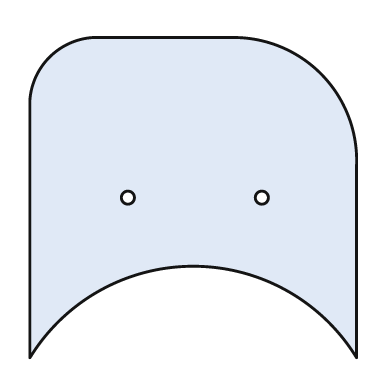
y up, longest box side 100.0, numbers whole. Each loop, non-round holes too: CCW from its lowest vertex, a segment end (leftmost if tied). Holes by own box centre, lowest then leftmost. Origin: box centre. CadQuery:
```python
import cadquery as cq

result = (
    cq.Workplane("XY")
    .moveTo(-50.0, -49.0)
    .threePointArc((0.0, -21.0), (50.0, -49.0))
    .lineTo(50.0, 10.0)
    .threePointArc((39.0, 38.0), (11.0, 49.0))
    .lineTo(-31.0, 49.0)
    .threePointArc((-44.0, 43.0), (-50.0, 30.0))
    .close()
    .moveTo(-20.0, 0.0)
    .circle(2.0)
    .moveTo(21.0, 0.0)
    .circle(2.0)
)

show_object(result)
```